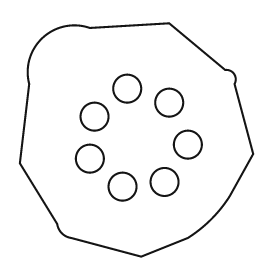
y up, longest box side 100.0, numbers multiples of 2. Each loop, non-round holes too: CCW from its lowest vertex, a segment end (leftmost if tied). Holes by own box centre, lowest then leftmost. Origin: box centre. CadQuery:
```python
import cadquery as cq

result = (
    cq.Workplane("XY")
    .moveTo(2.0, -50.0)
    .lineTo(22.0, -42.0)
    .threePointArc((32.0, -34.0), (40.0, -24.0))
    .lineTo(50.0, -6.0)
    .lineTo(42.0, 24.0)
    .threePointArc((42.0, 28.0), (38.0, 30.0))
    .lineTo(14.0, 50.0)
    .lineTo(-20.0, 48.0)
    .threePointArc((-40.0, 44.0), (-46.0, 24.0))
    .lineTo(-50.0, -10.0)
    .lineTo(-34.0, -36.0)
    .threePointArc((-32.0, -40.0), (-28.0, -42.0))
    .close()
    .moveTo(-6.0, -20.0)
    .circle(6.0)
    .moveTo(12.0, -18.0)
    .circle(6.0)
    .moveTo(-20.0, -8.0)
    .circle(6.0)
    .moveTo(22.0, -2.0)
    .circle(6.0)
    .moveTo(-18.0, 10.0)
    .circle(6.0)
    .moveTo(14.0, 16.0)
    .circle(6.0)
    .moveTo(-4.0, 22.0)
    .circle(6.0)
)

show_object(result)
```